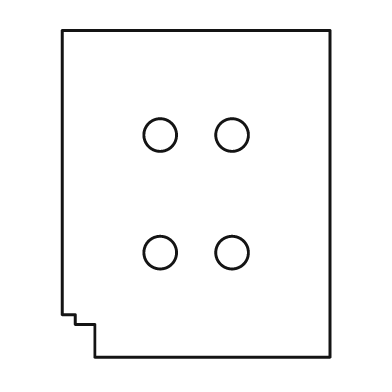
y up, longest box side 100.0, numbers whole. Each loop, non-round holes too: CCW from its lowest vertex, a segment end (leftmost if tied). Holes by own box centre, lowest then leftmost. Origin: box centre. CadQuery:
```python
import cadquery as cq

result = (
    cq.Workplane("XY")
    .moveTo(-31.0, -50.0)
    .lineTo(41.0, -50.0)
    .lineTo(41.0, 50.0)
    .lineTo(-41.0, 50.0)
    .lineTo(-41.0, -37.0)
    .lineTo(-37.0, -37.0)
    .lineTo(-37.0, -40.0)
    .lineTo(-31.0, -40.0)
    .close()
    .moveTo(-11.0, -18.0)
    .circle(5.0)
    .moveTo(11.0, -18.0)
    .circle(5.0)
    .moveTo(-11.0, 18.0)
    .circle(5.0)
    .moveTo(11.0, 18.0)
    .circle(5.0)
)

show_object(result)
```